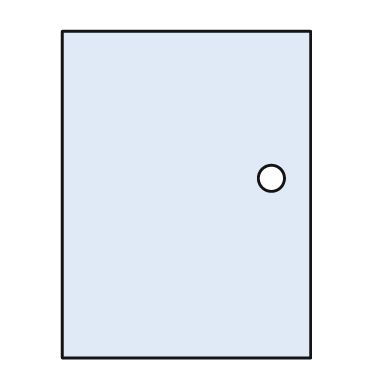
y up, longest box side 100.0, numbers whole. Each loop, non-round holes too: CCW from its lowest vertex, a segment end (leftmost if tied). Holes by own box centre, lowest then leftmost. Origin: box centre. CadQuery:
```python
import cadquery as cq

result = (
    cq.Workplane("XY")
    .moveTo(-38.0, -50.0)
    .lineTo(38.0, -50.0)
    .lineTo(38.0, 50.0)
    .lineTo(-38.0, 50.0)
    .close()
    .moveTo(26.0, 5.0)
    .circle(4.0)
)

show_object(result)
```